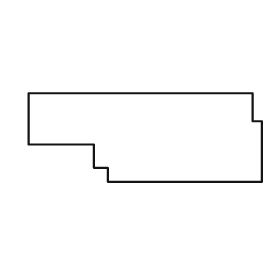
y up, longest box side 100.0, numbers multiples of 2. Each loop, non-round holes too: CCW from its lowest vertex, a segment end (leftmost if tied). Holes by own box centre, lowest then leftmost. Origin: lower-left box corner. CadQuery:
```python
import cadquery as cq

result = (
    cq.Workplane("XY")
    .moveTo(34.0, 0.0)
    .lineTo(100.0, 0.0)
    .lineTo(100.0, 26.0)
    .lineTo(96.0, 26.0)
    .lineTo(96.0, 38.0)
    .lineTo(0.0, 38.0)
    .lineTo(0.0, 16.0)
    .lineTo(28.0, 16.0)
    .lineTo(28.0, 6.0)
    .lineTo(34.0, 6.0)
    .close()
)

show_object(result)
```